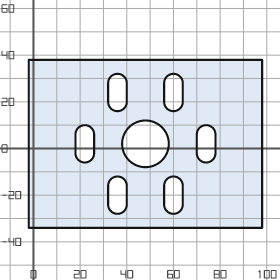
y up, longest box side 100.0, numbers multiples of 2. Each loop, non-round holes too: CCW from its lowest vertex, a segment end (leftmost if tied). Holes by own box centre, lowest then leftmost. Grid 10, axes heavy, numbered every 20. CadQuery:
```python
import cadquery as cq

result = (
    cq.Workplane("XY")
    .moveTo(-2.0, -34.0)
    .lineTo(98.0, -34.0)
    .lineTo(98.0, 38.0)
    .lineTo(-2.0, 38.0)
    .close()
    .moveTo(32.0, -24.0)
    .threePointArc((36.0, -28.0), (40.0, -24.0))
    .lineTo(40.0, -16.0)
    .threePointArc((36.0, -12.0), (32.0, -16.0))
    .close()
    .moveTo(56.0, -24.0)
    .threePointArc((60.0, -28.0), (64.0, -24.0))
    .lineTo(64.0, -16.0)
    .threePointArc((60.0, -12.0), (56.0, -16.0))
    .close()
    .moveTo(18.0, -2.0)
    .threePointArc((22.0, -6.0), (26.0, -2.0))
    .lineTo(26.0, 6.0)
    .threePointArc((22.0, 10.0), (18.0, 6.0))
    .close()
    .moveTo(48.0, 2.0)
    .circle(10.0)
    .moveTo(70.0, -2.0)
    .threePointArc((74.0, -6.0), (78.0, -2.0))
    .lineTo(78.0, 6.0)
    .threePointArc((74.0, 10.0), (70.0, 6.0))
    .close()
    .moveTo(32.0, 20.0)
    .threePointArc((36.0, 16.0), (40.0, 20.0))
    .lineTo(40.0, 28.0)
    .threePointArc((36.0, 32.0), (32.0, 28.0))
    .close()
    .moveTo(56.0, 20.0)
    .threePointArc((60.0, 16.0), (64.0, 20.0))
    .lineTo(64.0, 28.0)
    .threePointArc((60.0, 32.0), (56.0, 28.0))
    .close()
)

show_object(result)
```